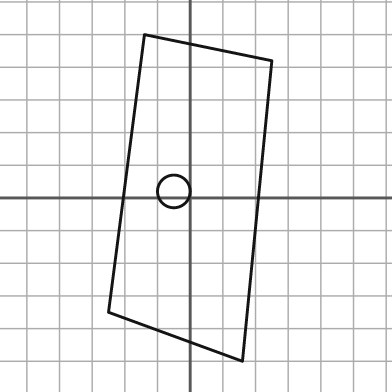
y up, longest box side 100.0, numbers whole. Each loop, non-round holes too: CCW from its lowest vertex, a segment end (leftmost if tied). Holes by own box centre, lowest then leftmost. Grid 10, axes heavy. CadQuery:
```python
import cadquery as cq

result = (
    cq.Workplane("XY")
    .moveTo(16.0, -50.0)
    .lineTo(25.0, 42.0)
    .lineTo(-14.0, 50.0)
    .lineTo(-25.0, -35.0)
    .close()
    .moveTo(-5.0, 2.0)
    .circle(5.0)
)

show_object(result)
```